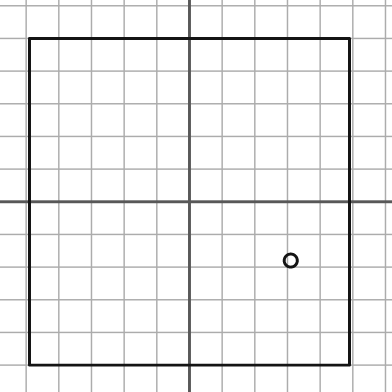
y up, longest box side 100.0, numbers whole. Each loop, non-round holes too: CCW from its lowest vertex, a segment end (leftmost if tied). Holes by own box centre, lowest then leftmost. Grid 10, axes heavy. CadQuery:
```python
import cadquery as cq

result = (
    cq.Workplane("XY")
    .moveTo(-49.0, -50.0)
    .lineTo(49.0, -50.0)
    .lineTo(49.0, 50.0)
    .lineTo(-49.0, 50.0)
    .close()
    .moveTo(31.0, -18.0)
    .circle(2.0)
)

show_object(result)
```